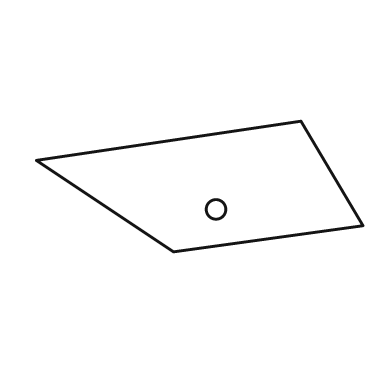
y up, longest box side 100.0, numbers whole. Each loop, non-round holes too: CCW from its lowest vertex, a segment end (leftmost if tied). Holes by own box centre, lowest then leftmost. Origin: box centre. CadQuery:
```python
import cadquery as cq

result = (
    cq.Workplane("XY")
    .moveTo(-8.0, -20.0)
    .lineTo(50.0, -12.0)
    .lineTo(31.0, 20.0)
    .lineTo(-50.0, 8.0)
    .close()
    .moveTo(5.0, -7.0)
    .circle(3.0)
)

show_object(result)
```